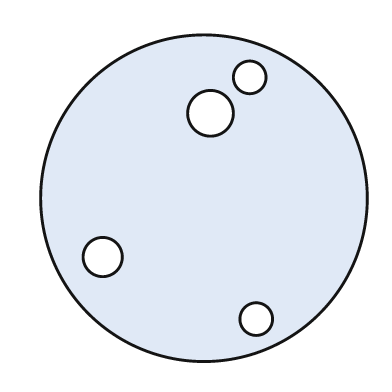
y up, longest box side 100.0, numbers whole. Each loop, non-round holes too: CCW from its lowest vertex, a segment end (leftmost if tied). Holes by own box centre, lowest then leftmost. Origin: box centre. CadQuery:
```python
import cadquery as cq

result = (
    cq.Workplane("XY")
    .moveTo(0.0, 0.0)
    .circle(50.0)
    .moveTo(16.0, -37.0)
    .circle(5.0)
    .moveTo(-31.0, -18.0)
    .circle(6.0)
    .moveTo(2.0, 26.0)
    .circle(7.0)
    .moveTo(14.0, 37.0)
    .circle(5.0)
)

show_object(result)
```